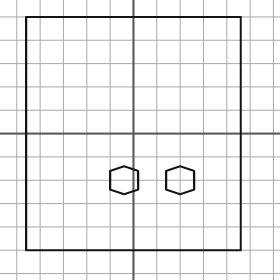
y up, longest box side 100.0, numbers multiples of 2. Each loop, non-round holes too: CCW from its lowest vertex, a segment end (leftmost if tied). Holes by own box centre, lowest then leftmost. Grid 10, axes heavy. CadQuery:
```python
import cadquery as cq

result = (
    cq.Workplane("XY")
    .moveTo(-46.0, -50.0)
    .lineTo(46.0, -50.0)
    .lineTo(46.0, 50.0)
    .lineTo(-46.0, 50.0)
    .close()
    .moveTo(-4.0, -26.0)
    .lineTo(2.0, -24.0)
    .lineTo(2.0, -16.0)
    .lineTo(-4.0, -14.0)
    .lineTo(-10.0, -16.0)
    .lineTo(-10.0, -24.0)
    .close()
    .moveTo(20.0, -26.0)
    .lineTo(26.0, -24.0)
    .lineTo(26.0, -16.0)
    .lineTo(20.0, -14.0)
    .lineTo(14.0, -16.0)
    .lineTo(14.0, -24.0)
    .close()
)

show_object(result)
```